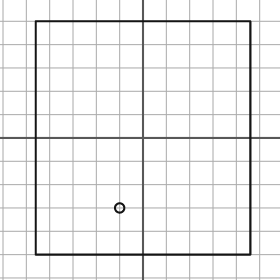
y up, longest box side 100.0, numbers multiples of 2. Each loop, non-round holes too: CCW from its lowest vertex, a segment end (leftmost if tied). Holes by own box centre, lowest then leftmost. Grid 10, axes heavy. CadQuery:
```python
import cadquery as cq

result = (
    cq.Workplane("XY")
    .moveTo(-46.0, -50.0)
    .lineTo(46.0, -50.0)
    .lineTo(46.0, 50.0)
    .lineTo(-46.0, 50.0)
    .close()
    .moveTo(-10.0, -30.0)
    .circle(2.0)
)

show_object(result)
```